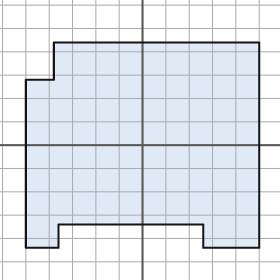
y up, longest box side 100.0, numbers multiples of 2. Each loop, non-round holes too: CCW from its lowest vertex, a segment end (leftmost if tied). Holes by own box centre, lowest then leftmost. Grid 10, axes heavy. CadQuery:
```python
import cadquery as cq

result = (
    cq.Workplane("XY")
    .moveTo(-50.0, -44.0)
    .lineTo(-36.0, -44.0)
    .lineTo(-36.0, -34.0)
    .lineTo(26.0, -34.0)
    .lineTo(26.0, -44.0)
    .lineTo(50.0, -44.0)
    .lineTo(50.0, 44.0)
    .lineTo(-38.0, 44.0)
    .lineTo(-38.0, 28.0)
    .lineTo(-50.0, 28.0)
    .close()
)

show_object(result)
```